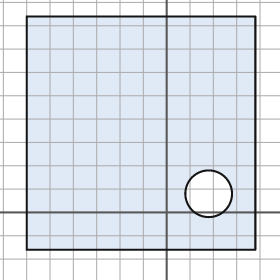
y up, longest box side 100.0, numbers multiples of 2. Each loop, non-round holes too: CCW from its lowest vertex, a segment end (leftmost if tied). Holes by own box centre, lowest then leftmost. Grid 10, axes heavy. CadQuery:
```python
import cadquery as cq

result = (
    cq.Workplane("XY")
    .moveTo(-60.0, -16.0)
    .lineTo(38.0, -16.0)
    .lineTo(38.0, 84.0)
    .lineTo(-60.0, 84.0)
    .close()
    .moveTo(18.0, 8.0)
    .circle(10.0)
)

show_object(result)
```